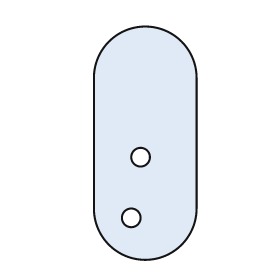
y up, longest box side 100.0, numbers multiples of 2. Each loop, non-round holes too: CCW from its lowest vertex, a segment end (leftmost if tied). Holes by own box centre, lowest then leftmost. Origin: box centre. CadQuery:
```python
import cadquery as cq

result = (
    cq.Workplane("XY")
    .moveTo(-22.0, -28.0)
    .threePointArc((0.0, -50.0), (22.0, -28.0))
    .lineTo(22.0, 28.0)
    .threePointArc((0.0, 50.0), (-22.0, 28.0))
    .close()
    .moveTo(-6.0, -32.0)
    .circle(4.0)
    .moveTo(-2.0, -6.0)
    .circle(4.0)
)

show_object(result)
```